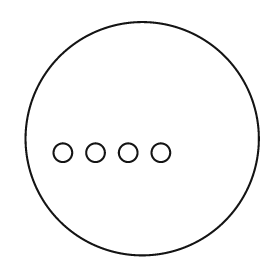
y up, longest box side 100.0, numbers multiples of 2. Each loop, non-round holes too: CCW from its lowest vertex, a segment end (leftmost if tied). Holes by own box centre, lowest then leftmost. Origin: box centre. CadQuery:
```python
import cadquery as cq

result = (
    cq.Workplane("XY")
    .moveTo(0.0, 0.0)
    .circle(50.0)
    .moveTo(-34.0, -6.0)
    .circle(4.0)
    .moveTo(-20.0, -6.0)
    .circle(4.0)
    .moveTo(-6.0, -6.0)
    .circle(4.0)
    .moveTo(8.0, -6.0)
    .circle(4.0)
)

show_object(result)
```